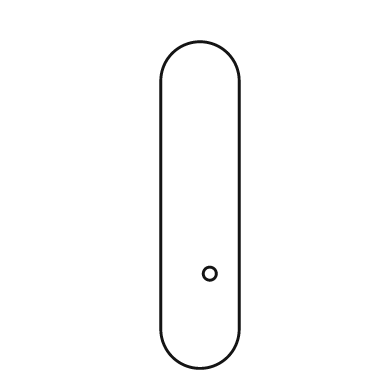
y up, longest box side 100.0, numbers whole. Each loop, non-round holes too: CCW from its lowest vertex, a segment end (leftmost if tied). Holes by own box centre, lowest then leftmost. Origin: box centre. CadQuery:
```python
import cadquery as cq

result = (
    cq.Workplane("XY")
    .moveTo(-12.0, -38.0)
    .threePointArc((0.0, -50.0), (12.0, -38.0))
    .lineTo(12.0, 38.0)
    .threePointArc((0.0, 50.0), (-12.0, 38.0))
    .close()
    .moveTo(3.0, -21.0)
    .circle(2.0)
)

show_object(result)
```